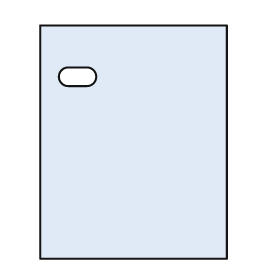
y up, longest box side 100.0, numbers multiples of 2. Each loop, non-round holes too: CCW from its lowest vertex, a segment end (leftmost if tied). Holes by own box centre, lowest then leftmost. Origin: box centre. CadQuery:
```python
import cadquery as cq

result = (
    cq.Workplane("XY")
    .moveTo(-40.0, -50.0)
    .lineTo(40.0, -50.0)
    .lineTo(40.0, 50.0)
    .lineTo(-40.0, 50.0)
    .close()
    .moveTo(-28.0, 24.0)
    .lineTo(-20.0, 24.0)
    .threePointArc((-16.0, 28.0), (-20.0, 32.0))
    .lineTo(-28.0, 32.0)
    .threePointArc((-32.0, 28.0), (-28.0, 24.0))
    .close()
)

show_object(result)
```